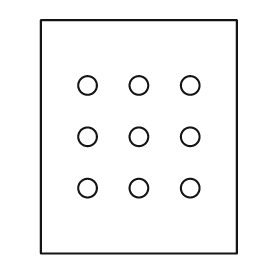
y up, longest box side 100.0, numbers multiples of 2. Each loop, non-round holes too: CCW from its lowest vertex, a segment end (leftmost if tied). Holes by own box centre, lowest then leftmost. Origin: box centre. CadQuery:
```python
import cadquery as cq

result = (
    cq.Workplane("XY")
    .moveTo(-42.0, -50.0)
    .lineTo(42.0, -50.0)
    .lineTo(42.0, 50.0)
    .lineTo(-42.0, 50.0)
    .close()
    .moveTo(-22.0, -22.0)
    .circle(4.0)
    .moveTo(0.0, -22.0)
    .circle(4.0)
    .moveTo(22.0, -22.0)
    .circle(4.0)
    .moveTo(-22.0, 0.0)
    .circle(4.0)
    .moveTo(0.0, 0.0)
    .circle(4.0)
    .moveTo(22.0, 0.0)
    .circle(4.0)
    .moveTo(-22.0, 22.0)
    .circle(4.0)
    .moveTo(0.0, 22.0)
    .circle(4.0)
    .moveTo(22.0, 22.0)
    .circle(4.0)
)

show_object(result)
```